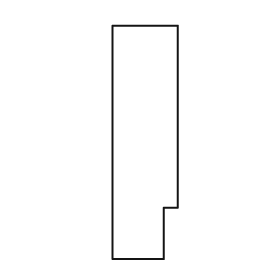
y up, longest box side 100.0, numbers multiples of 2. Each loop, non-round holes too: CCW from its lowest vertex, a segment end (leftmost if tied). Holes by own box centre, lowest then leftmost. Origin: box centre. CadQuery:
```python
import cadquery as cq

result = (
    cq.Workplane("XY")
    .moveTo(-14.0, -50.0)
    .lineTo(8.0, -50.0)
    .lineTo(8.0, -28.0)
    .lineTo(14.0, -28.0)
    .lineTo(14.0, 50.0)
    .lineTo(-14.0, 50.0)
    .close()
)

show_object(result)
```